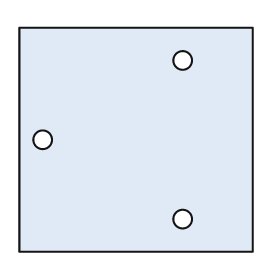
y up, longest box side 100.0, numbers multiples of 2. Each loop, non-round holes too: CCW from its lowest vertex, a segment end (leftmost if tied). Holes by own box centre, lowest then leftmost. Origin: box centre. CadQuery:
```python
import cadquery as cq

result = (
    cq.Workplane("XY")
    .moveTo(-50.0, -48.0)
    .lineTo(50.0, -48.0)
    .lineTo(50.0, 48.0)
    .lineTo(-50.0, 48.0)
    .close()
    .moveTo(20.0, -34.0)
    .circle(4.0)
    .moveTo(-40.0, 0.0)
    .circle(4.0)
    .moveTo(20.0, 34.0)
    .circle(4.0)
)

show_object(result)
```